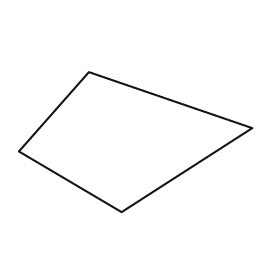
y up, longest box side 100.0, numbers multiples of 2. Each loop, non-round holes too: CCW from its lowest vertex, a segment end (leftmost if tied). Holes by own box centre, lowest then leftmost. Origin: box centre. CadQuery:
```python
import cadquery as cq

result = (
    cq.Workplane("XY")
    .moveTo(-6.0, -30.0)
    .lineTo(50.0, 6.0)
    .lineTo(-20.0, 30.0)
    .lineTo(-50.0, -4.0)
    .close()
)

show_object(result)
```